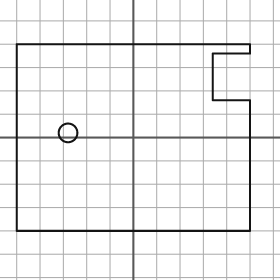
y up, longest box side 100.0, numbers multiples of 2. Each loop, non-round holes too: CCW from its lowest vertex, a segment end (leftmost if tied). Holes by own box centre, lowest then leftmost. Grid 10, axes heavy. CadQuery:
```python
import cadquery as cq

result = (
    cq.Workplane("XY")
    .moveTo(-50.0, -40.0)
    .lineTo(50.0, -40.0)
    .lineTo(50.0, 16.0)
    .lineTo(34.0, 16.0)
    .lineTo(34.0, 36.0)
    .lineTo(50.0, 36.0)
    .lineTo(50.0, 40.0)
    .lineTo(-50.0, 40.0)
    .close()
    .moveTo(-28.0, 2.0)
    .circle(4.0)
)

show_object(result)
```